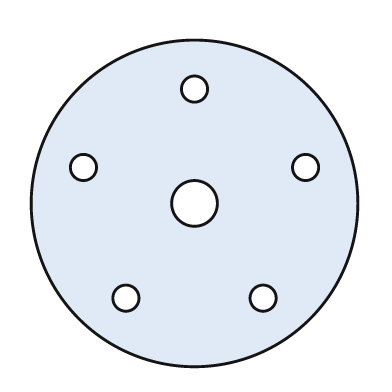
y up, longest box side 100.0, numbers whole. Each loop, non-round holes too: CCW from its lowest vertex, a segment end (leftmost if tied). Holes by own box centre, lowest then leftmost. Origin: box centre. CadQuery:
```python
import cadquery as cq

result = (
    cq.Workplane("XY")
    .moveTo(0.0, 0.0)
    .circle(50.0)
    .moveTo(-21.0, -29.0)
    .circle(4.0)
    .moveTo(21.0, -29.0)
    .circle(4.0)
    .moveTo(0.0, 0.0)
    .circle(7.0)
    .moveTo(-34.0, 11.0)
    .circle(4.0)
    .moveTo(34.0, 11.0)
    .circle(4.0)
    .moveTo(0.0, 35.0)
    .circle(4.0)
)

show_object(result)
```